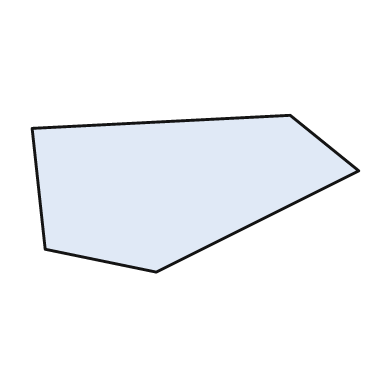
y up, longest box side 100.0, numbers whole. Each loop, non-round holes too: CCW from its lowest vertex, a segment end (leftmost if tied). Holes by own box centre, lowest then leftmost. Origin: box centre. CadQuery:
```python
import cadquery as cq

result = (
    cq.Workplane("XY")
    .moveTo(-12.0, -24.0)
    .lineTo(50.0, 7.0)
    .lineTo(29.0, 24.0)
    .lineTo(-50.0, 20.0)
    .lineTo(-46.0, -17.0)
    .close()
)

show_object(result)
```